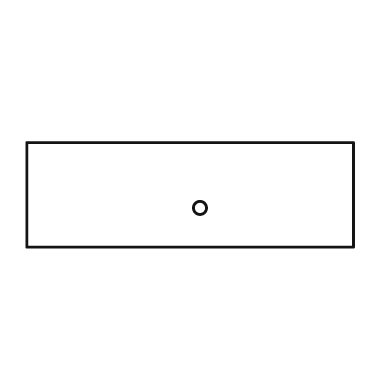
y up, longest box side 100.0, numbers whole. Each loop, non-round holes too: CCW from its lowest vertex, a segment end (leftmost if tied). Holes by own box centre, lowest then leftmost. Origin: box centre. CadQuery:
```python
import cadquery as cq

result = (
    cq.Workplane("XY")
    .moveTo(-50.0, -16.0)
    .lineTo(50.0, -16.0)
    .lineTo(50.0, 16.0)
    .lineTo(-50.0, 16.0)
    .close()
    .moveTo(3.0, -4.0)
    .circle(2.0)
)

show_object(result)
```